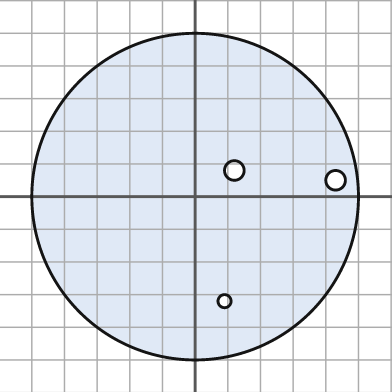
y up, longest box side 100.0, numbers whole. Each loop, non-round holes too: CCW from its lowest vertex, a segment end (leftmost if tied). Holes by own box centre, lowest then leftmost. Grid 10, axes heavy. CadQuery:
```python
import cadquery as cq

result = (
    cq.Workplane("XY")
    .moveTo(0.0, 0.0)
    .circle(50.0)
    .moveTo(9.0, -32.0)
    .circle(2.0)
    .moveTo(43.0, 5.0)
    .circle(3.0)
    .moveTo(12.0, 8.0)
    .circle(3.0)
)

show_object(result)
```